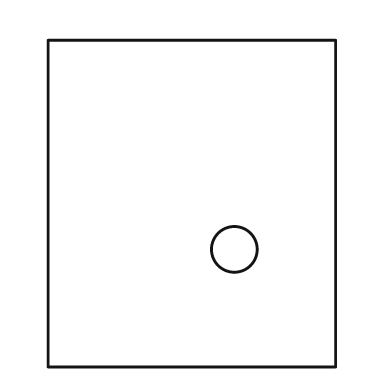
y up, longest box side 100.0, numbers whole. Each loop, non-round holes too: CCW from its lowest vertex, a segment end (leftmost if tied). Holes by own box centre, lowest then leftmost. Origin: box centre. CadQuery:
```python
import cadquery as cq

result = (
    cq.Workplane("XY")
    .moveTo(-44.0, -50.0)
    .lineTo(44.0, -50.0)
    .lineTo(44.0, 50.0)
    .lineTo(-44.0, 50.0)
    .close()
    .moveTo(13.0, -14.0)
    .circle(7.0)
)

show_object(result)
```